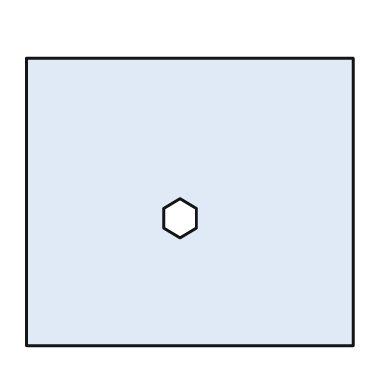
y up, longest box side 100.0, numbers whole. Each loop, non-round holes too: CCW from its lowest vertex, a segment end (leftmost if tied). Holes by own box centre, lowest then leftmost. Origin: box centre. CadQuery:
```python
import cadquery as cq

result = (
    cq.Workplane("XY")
    .moveTo(-50.0, -44.0)
    .lineTo(50.0, -44.0)
    .lineTo(50.0, 44.0)
    .lineTo(-50.0, 44.0)
    .close()
    .moveTo(-3.0, -11.0)
    .lineTo(2.0, -8.0)
    .lineTo(2.0, -2.0)
    .lineTo(-3.0, 1.0)
    .lineTo(-8.0, -2.0)
    .lineTo(-8.0, -8.0)
    .close()
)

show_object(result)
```